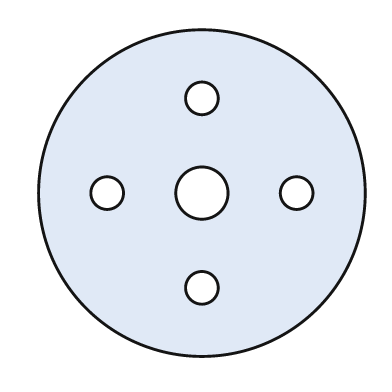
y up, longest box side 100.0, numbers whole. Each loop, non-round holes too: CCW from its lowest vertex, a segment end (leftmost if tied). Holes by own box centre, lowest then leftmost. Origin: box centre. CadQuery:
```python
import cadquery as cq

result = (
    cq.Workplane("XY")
    .moveTo(0.0, 0.0)
    .circle(50.0)
    .moveTo(0.0, -29.0)
    .circle(5.0)
    .moveTo(-29.0, 0.0)
    .circle(5.0)
    .moveTo(0.0, 0.0)
    .circle(8.0)
    .moveTo(29.0, 0.0)
    .circle(5.0)
    .moveTo(0.0, 29.0)
    .circle(5.0)
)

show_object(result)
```